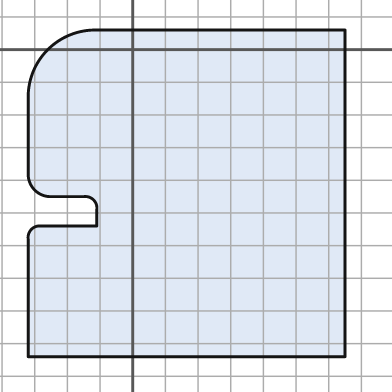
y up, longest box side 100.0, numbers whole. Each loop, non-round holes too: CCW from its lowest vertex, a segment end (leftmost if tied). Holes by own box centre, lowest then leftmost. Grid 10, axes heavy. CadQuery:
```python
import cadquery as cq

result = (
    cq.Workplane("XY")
    .moveTo(-32.0, -94.0)
    .lineTo(65.0, -94.0)
    .lineTo(65.0, 6.0)
    .lineTo(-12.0, 6.0)
    .threePointArc((-26.0, 0.0), (-32.0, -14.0))
    .lineTo(-32.0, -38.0)
    .threePointArc((-30.0, -43.0), (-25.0, -45.0))
    .lineTo(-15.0, -45.0)
    .threePointArc((-12.0, -46.0), (-11.0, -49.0))
    .lineTo(-11.0, -54.0)
    .lineTo(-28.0, -54.0)
    .threePointArc((-31.0, -55.0), (-32.0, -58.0))
    .close()
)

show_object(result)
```